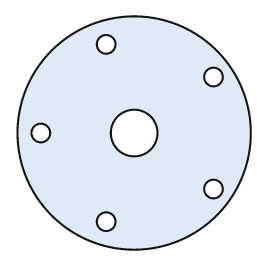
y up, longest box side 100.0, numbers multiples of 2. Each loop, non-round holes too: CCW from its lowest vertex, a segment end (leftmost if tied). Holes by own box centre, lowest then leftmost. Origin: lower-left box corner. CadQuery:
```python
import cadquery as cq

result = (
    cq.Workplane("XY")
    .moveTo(50.0, 50.0)
    .circle(50.0)
    .moveTo(38.0, 12.0)
    .circle(4.0)
    .moveTo(84.0, 26.0)
    .circle(4.0)
    .moveTo(10.0, 50.0)
    .circle(4.0)
    .moveTo(50.0, 50.0)
    .circle(10.0)
    .moveTo(84.0, 74.0)
    .circle(4.0)
    .moveTo(38.0, 88.0)
    .circle(4.0)
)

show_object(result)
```